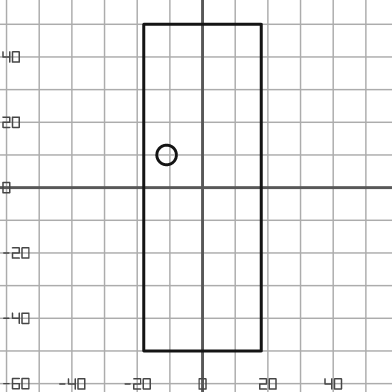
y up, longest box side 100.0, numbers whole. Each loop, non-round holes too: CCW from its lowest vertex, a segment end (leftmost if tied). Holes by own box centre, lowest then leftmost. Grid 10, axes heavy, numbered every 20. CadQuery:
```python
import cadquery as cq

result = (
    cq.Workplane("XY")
    .moveTo(-18.0, -50.0)
    .lineTo(18.0, -50.0)
    .lineTo(18.0, 50.0)
    .lineTo(-18.0, 50.0)
    .close()
    .moveTo(-11.0, 10.0)
    .circle(3.0)
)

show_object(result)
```